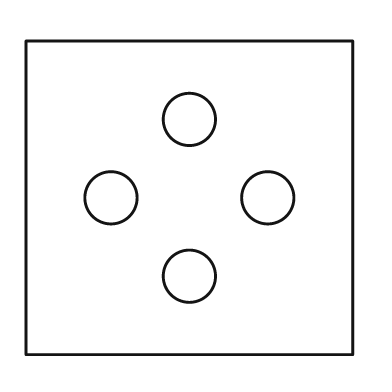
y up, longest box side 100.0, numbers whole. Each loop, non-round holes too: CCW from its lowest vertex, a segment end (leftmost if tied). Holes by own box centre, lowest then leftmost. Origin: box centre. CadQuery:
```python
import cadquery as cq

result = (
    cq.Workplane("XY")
    .moveTo(-50.0, -48.0)
    .lineTo(50.0, -48.0)
    .lineTo(50.0, 48.0)
    .lineTo(-50.0, 48.0)
    .close()
    .moveTo(0.0, -24.0)
    .circle(8.0)
    .moveTo(-24.0, 0.0)
    .circle(8.0)
    .moveTo(24.0, 0.0)
    .circle(8.0)
    .moveTo(0.0, 24.0)
    .circle(8.0)
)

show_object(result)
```